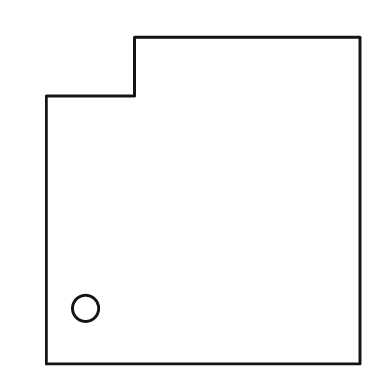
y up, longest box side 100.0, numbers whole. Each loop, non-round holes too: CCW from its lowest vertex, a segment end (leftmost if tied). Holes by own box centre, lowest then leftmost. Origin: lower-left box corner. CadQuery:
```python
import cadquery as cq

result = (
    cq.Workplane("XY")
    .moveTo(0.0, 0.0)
    .lineTo(96.0, 0.0)
    .lineTo(96.0, 100.0)
    .lineTo(27.0, 100.0)
    .lineTo(27.0, 82.0)
    .lineTo(0.0, 82.0)
    .close()
    .moveTo(12.0, 17.0)
    .circle(4.0)
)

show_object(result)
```